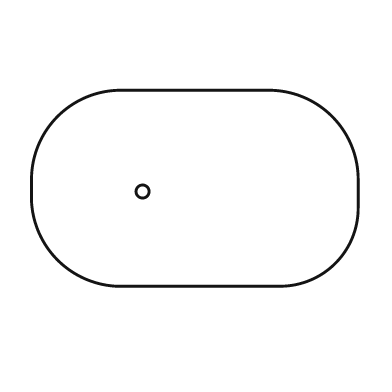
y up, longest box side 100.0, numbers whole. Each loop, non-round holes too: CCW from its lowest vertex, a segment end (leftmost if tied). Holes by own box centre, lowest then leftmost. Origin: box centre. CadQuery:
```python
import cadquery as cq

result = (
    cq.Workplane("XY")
    .moveTo(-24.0, -30.0)
    .lineTo(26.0, -30.0)
    .threePointArc((43.0, -23.0), (50.0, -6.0))
    .lineTo(50.0, 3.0)
    .threePointArc((42.0, 22.0), (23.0, 30.0))
    .lineTo(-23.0, 30.0)
    .threePointArc((-42.0, 22.0), (-50.0, 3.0))
    .lineTo(-50.0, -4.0)
    .threePointArc((-42.0, -22.0), (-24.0, -30.0))
    .close()
    .moveTo(-16.0, -1.0)
    .circle(2.0)
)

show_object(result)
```